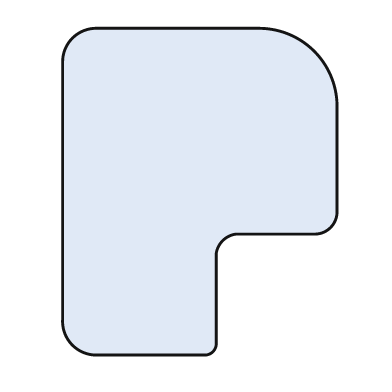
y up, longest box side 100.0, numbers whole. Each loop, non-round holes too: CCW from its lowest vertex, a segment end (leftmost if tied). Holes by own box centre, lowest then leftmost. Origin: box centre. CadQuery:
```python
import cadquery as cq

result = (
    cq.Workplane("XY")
    .moveTo(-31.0, -50.0)
    .lineTo(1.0, -50.0)
    .threePointArc((4.0, -49.0), (5.0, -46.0))
    .lineTo(5.0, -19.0)
    .threePointArc((7.0, -15.0), (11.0, -13.0))
    .lineTo(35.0, -13.0)
    .threePointArc((40.0, -11.0), (42.0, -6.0))
    .lineTo(42.0, 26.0)
    .threePointArc((35.0, 43.0), (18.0, 50.0))
    .lineTo(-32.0, 50.0)
    .threePointArc((-39.0, 47.0), (-42.0, 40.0))
    .lineTo(-42.0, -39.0)
    .threePointArc((-39.0, -47.0), (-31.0, -50.0))
    .close()
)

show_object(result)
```